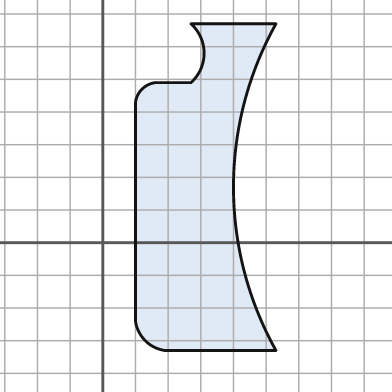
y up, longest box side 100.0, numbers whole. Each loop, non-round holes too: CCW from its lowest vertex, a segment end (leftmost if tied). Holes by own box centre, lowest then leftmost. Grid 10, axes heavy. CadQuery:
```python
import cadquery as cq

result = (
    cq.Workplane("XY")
    .moveTo(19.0, -33.0)
    .lineTo(53.0, -33.0)
    .threePointArc((40.0, 17.0), (53.0, 67.0))
    .lineTo(27.0, 67.0)
    .threePointArc((31.0, 58.0), (27.0, 49.0))
    .lineTo(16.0, 49.0)
    .threePointArc((12.0, 47.0), (10.0, 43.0))
    .lineTo(10.0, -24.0)
    .threePointArc((13.0, -30.0), (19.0, -33.0))
    .close()
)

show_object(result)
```